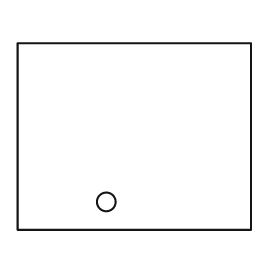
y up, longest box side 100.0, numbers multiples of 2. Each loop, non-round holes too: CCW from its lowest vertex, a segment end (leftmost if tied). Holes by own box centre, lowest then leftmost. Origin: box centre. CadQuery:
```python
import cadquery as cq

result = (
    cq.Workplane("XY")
    .moveTo(-50.0, -40.0)
    .lineTo(50.0, -40.0)
    .lineTo(50.0, 40.0)
    .lineTo(-50.0, 40.0)
    .close()
    .moveTo(-12.0, -28.0)
    .circle(4.0)
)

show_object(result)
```